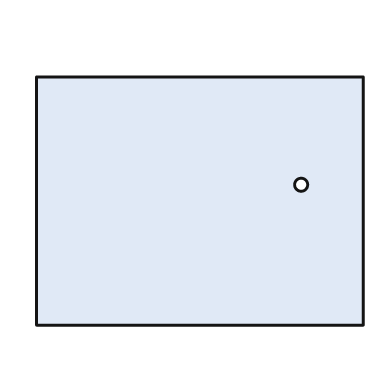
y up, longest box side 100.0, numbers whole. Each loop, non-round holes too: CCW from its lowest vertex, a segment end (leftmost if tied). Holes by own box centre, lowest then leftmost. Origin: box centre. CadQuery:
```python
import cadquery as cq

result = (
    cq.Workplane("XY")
    .moveTo(-50.0, -38.0)
    .lineTo(50.0, -38.0)
    .lineTo(50.0, 38.0)
    .lineTo(-50.0, 38.0)
    .close()
    .moveTo(31.0, 5.0)
    .circle(2.0)
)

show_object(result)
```